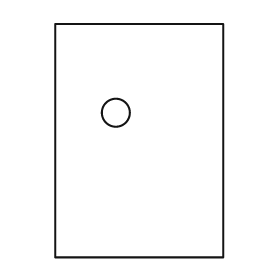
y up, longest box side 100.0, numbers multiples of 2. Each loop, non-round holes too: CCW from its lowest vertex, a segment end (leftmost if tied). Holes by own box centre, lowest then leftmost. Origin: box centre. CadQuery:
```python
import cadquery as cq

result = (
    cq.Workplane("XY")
    .moveTo(-36.0, -50.0)
    .lineTo(36.0, -50.0)
    .lineTo(36.0, 50.0)
    .lineTo(-36.0, 50.0)
    .close()
    .moveTo(-10.0, 12.0)
    .circle(6.0)
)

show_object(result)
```